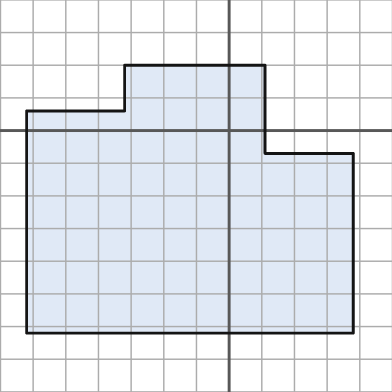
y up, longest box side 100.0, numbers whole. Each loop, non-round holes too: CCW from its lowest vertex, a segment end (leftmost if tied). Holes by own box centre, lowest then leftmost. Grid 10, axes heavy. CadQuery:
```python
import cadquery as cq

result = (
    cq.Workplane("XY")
    .moveTo(-62.0, -62.0)
    .lineTo(38.0, -62.0)
    .lineTo(38.0, -7.0)
    .lineTo(11.0, -7.0)
    .lineTo(11.0, 20.0)
    .lineTo(-32.0, 20.0)
    .lineTo(-32.0, 6.0)
    .lineTo(-62.0, 6.0)
    .close()
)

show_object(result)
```